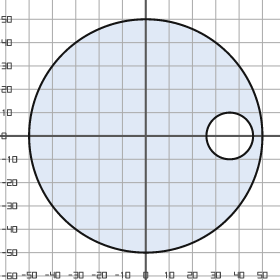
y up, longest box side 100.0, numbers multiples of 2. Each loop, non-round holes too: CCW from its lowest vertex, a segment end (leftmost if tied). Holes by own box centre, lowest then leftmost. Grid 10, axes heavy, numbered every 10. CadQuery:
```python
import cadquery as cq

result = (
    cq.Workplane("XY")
    .moveTo(0.0, 0.0)
    .circle(50.0)
    .moveTo(36.0, 0.0)
    .circle(10.0)
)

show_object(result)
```